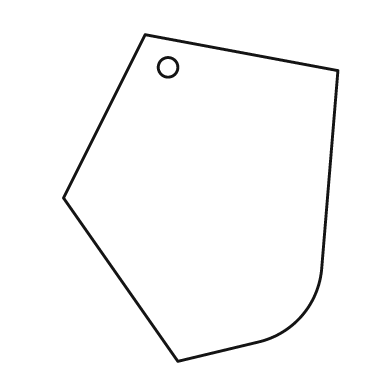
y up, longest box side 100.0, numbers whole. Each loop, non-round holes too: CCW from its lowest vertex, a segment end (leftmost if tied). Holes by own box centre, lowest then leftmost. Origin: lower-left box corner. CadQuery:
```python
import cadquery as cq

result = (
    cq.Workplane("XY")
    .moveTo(35.0, 0.0)
    .lineTo(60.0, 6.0)
    .threePointArc((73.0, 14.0), (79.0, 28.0))
    .lineTo(84.0, 89.0)
    .lineTo(25.0, 100.0)
    .lineTo(0.0, 50.0)
    .close()
    .moveTo(32.0, 90.0)
    .circle(3.0)
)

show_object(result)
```